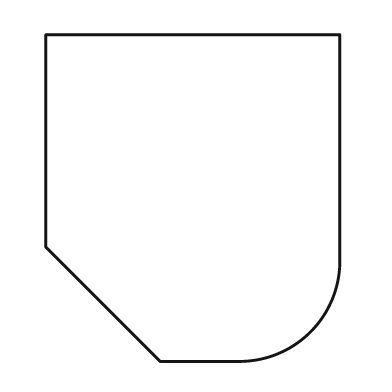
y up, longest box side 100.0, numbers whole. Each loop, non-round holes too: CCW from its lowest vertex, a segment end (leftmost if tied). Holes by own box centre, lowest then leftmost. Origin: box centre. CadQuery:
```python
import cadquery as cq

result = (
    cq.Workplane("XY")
    .moveTo(-10.0, -50.0)
    .lineTo(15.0, -50.0)
    .threePointArc((36.0, -41.0), (45.0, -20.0))
    .lineTo(45.0, 50.0)
    .lineTo(-45.0, 50.0)
    .lineTo(-45.0, -15.0)
    .close()
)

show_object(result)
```